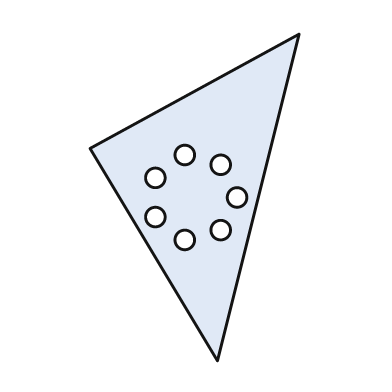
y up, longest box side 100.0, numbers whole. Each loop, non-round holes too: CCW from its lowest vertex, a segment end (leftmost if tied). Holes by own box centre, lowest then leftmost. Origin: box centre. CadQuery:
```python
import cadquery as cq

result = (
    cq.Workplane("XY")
    .moveTo(7.0, -50.0)
    .lineTo(32.0, 50.0)
    .lineTo(-32.0, 15.0)
    .close()
    .moveTo(-3.0, -13.0)
    .circle(3.0)
    .moveTo(8.0, -10.0)
    .circle(3.0)
    .moveTo(-12.0, -6.0)
    .circle(3.0)
    .moveTo(13.0, 0.0)
    .circle(3.0)
    .moveTo(-12.0, 6.0)
    .circle(3.0)
    .moveTo(8.0, 10.0)
    .circle(3.0)
    .moveTo(-3.0, 13.0)
    .circle(3.0)
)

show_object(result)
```